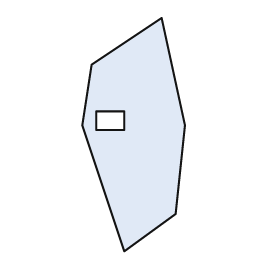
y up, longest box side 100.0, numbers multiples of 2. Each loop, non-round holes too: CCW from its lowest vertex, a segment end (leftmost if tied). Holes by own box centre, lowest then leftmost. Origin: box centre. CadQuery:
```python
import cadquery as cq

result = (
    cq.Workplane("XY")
    .moveTo(-4.0, -50.0)
    .lineTo(18.0, -34.0)
    .lineTo(22.0, 4.0)
    .lineTo(12.0, 50.0)
    .lineTo(-18.0, 30.0)
    .lineTo(-22.0, 4.0)
    .close()
    .moveTo(-16.0, 2.0)
    .lineTo(-4.0, 2.0)
    .lineTo(-4.0, 10.0)
    .lineTo(-16.0, 10.0)
    .close()
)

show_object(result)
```